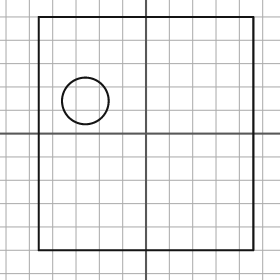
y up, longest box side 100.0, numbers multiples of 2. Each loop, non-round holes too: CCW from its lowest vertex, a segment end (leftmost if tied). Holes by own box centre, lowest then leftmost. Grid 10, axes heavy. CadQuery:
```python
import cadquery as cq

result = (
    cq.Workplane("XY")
    .moveTo(-46.0, -50.0)
    .lineTo(46.0, -50.0)
    .lineTo(46.0, 50.0)
    .lineTo(-46.0, 50.0)
    .close()
    .moveTo(-26.0, 14.0)
    .circle(10.0)
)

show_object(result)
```